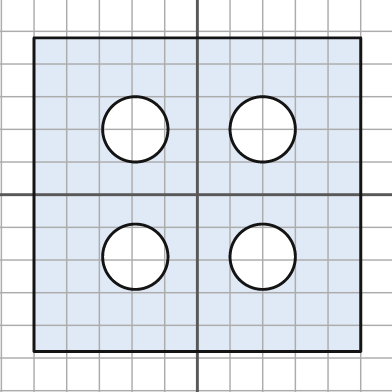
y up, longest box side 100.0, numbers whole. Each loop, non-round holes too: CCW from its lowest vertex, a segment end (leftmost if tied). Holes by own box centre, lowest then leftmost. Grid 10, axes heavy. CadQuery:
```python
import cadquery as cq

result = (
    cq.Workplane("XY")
    .moveTo(-50.0, -48.0)
    .lineTo(50.0, -48.0)
    .lineTo(50.0, 48.0)
    .lineTo(-50.0, 48.0)
    .close()
    .moveTo(-19.0, -19.0)
    .circle(10.0)
    .moveTo(20.0, -19.0)
    .circle(10.0)
    .moveTo(-19.0, 20.0)
    .circle(10.0)
    .moveTo(20.0, 20.0)
    .circle(10.0)
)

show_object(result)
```